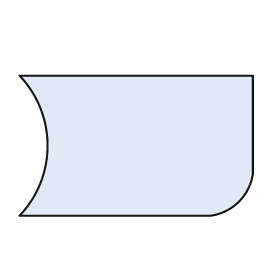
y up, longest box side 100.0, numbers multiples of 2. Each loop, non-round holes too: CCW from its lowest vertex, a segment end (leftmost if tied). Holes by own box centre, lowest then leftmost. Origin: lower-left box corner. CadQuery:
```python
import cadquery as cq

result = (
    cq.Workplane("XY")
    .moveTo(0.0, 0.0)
    .lineTo(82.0, 0.0)
    .threePointArc((94.0, 6.0), (100.0, 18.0))
    .lineTo(100.0, 60.0)
    .lineTo(0.0, 60.0)
    .threePointArc((12.0, 30.0), (0.0, 0.0))
    .close()
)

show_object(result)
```